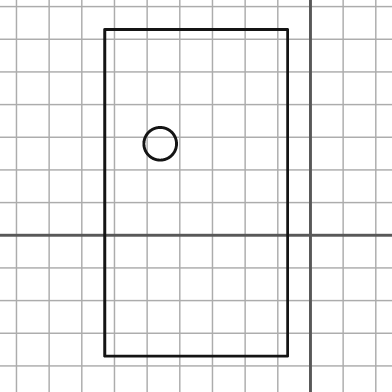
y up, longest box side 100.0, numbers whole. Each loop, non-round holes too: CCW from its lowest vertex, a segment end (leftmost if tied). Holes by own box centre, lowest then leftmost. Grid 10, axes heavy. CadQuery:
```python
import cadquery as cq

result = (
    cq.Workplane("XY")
    .moveTo(-63.0, -37.0)
    .lineTo(-7.0, -37.0)
    .lineTo(-7.0, 63.0)
    .lineTo(-63.0, 63.0)
    .close()
    .moveTo(-46.0, 28.0)
    .circle(5.0)
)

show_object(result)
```